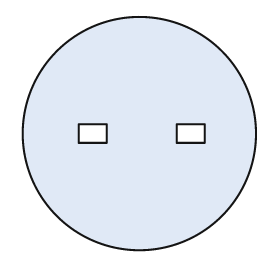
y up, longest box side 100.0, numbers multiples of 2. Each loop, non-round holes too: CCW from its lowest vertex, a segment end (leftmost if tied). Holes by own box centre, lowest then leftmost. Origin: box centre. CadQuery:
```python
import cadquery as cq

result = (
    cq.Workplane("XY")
    .moveTo(0.0, 0.0)
    .circle(50.0)
    .moveTo(-26.0, -4.0)
    .lineTo(-14.0, -4.0)
    .lineTo(-14.0, 4.0)
    .lineTo(-26.0, 4.0)
    .close()
    .moveTo(16.0, -4.0)
    .lineTo(28.0, -4.0)
    .lineTo(28.0, 4.0)
    .lineTo(16.0, 4.0)
    .close()
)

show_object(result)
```